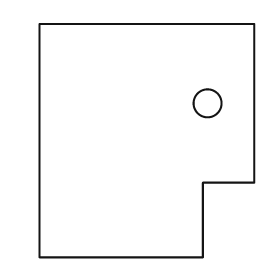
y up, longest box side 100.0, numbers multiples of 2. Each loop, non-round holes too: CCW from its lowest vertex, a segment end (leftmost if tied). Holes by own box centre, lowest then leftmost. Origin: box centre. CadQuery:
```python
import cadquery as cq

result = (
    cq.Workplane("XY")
    .moveTo(-46.0, -50.0)
    .lineTo(24.0, -50.0)
    .lineTo(24.0, -18.0)
    .lineTo(46.0, -18.0)
    .lineTo(46.0, 50.0)
    .lineTo(-46.0, 50.0)
    .close()
    .moveTo(26.0, 16.0)
    .circle(6.0)
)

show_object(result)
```